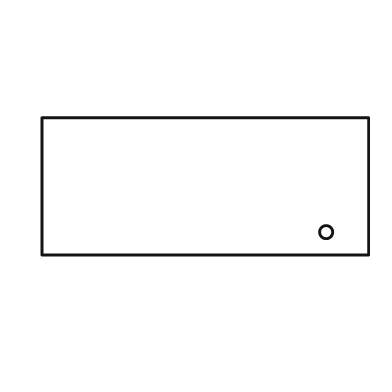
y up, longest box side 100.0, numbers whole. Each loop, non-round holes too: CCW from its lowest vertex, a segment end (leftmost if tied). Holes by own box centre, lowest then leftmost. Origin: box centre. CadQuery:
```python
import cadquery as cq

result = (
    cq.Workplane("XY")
    .moveTo(-50.0, -21.0)
    .lineTo(50.0, -21.0)
    .lineTo(50.0, 21.0)
    .lineTo(-50.0, 21.0)
    .close()
    .moveTo(37.0, -14.0)
    .circle(2.0)
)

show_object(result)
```